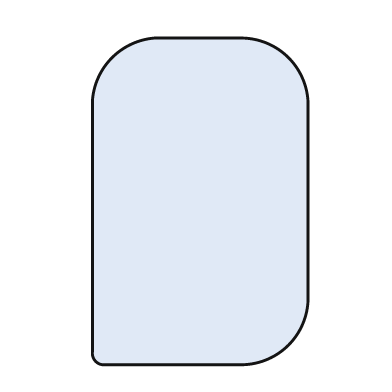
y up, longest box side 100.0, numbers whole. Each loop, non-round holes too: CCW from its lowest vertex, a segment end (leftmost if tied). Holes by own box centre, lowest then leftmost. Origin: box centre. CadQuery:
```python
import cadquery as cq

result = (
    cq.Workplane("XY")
    .moveTo(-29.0, -50.0)
    .lineTo(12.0, -50.0)
    .threePointArc((27.0, -44.0), (33.0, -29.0))
    .lineTo(33.0, 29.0)
    .threePointArc((27.0, 44.0), (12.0, 50.0))
    .lineTo(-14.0, 50.0)
    .threePointArc((-27.0, 44.0), (-33.0, 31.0))
    .lineTo(-33.0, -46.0)
    .threePointArc((-32.0, -49.0), (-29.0, -50.0))
    .close()
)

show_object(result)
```